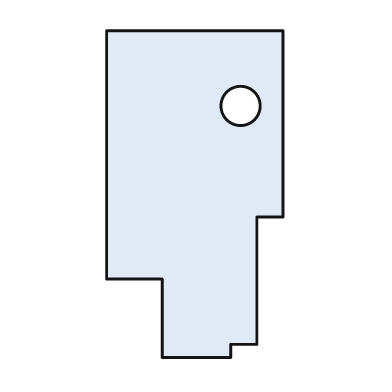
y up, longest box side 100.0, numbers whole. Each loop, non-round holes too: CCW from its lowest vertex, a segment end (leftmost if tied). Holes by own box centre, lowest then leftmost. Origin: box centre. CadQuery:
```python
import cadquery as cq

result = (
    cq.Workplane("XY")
    .moveTo(-10.0, -50.0)
    .lineTo(11.0, -50.0)
    .lineTo(11.0, -46.0)
    .lineTo(19.0, -46.0)
    .lineTo(19.0, -7.0)
    .lineTo(27.0, -7.0)
    .lineTo(27.0, 50.0)
    .lineTo(-27.0, 50.0)
    .lineTo(-27.0, -26.0)
    .lineTo(-10.0, -26.0)
    .close()
    .moveTo(14.0, 27.0)
    .circle(6.0)
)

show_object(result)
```